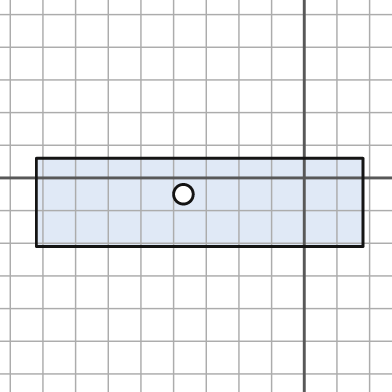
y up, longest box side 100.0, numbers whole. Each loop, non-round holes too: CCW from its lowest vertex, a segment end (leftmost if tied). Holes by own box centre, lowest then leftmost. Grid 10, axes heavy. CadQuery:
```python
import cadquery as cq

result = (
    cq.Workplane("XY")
    .moveTo(-82.0, -21.0)
    .lineTo(18.0, -21.0)
    .lineTo(18.0, 6.0)
    .lineTo(-82.0, 6.0)
    .close()
    .moveTo(-37.0, -5.0)
    .circle(3.0)
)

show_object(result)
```